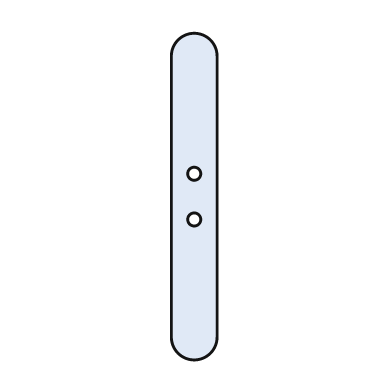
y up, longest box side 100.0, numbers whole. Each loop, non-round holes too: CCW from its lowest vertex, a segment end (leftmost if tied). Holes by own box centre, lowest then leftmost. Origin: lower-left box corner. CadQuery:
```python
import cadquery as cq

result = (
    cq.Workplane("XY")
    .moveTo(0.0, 7.0)
    .threePointArc((7.0, 0.0), (14.0, 7.0))
    .lineTo(14.0, 93.0)
    .threePointArc((7.0, 100.0), (0.0, 93.0))
    .close()
    .moveTo(7.0, 43.0)
    .circle(2.0)
    .moveTo(7.0, 57.0)
    .circle(2.0)
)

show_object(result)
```